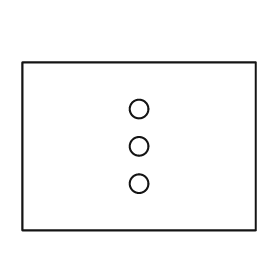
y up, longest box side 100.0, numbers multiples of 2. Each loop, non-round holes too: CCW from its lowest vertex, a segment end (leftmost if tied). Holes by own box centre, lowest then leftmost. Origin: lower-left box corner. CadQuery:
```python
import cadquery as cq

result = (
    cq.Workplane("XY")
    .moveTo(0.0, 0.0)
    .lineTo(100.0, 0.0)
    .lineTo(100.0, 72.0)
    .lineTo(0.0, 72.0)
    .close()
    .moveTo(50.0, 20.0)
    .circle(4.0)
    .moveTo(50.0, 36.0)
    .circle(4.0)
    .moveTo(50.0, 52.0)
    .circle(4.0)
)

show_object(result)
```